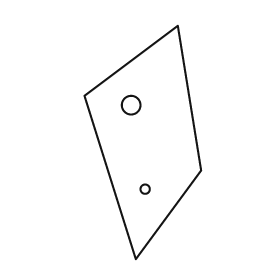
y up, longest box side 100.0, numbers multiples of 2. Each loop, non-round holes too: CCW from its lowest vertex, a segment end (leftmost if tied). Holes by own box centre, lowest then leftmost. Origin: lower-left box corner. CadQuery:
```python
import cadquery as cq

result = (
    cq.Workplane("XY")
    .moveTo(22.0, 0.0)
    .lineTo(50.0, 38.0)
    .lineTo(40.0, 100.0)
    .lineTo(0.0, 70.0)
    .close()
    .moveTo(26.0, 30.0)
    .circle(2.0)
    .moveTo(20.0, 66.0)
    .circle(4.0)
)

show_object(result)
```